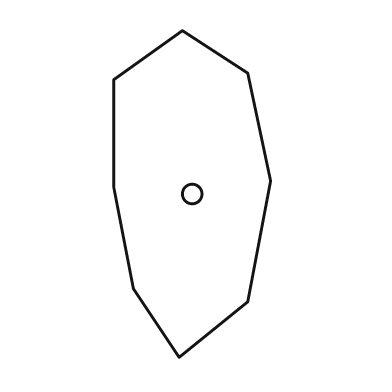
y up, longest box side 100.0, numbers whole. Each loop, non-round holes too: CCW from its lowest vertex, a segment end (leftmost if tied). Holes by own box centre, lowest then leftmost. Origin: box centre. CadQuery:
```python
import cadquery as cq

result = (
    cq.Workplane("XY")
    .moveTo(-4.0, -50.0)
    .lineTo(17.0, -33.0)
    .lineTo(24.0, 4.0)
    .lineTo(17.0, 37.0)
    .lineTo(-3.0, 50.0)
    .lineTo(-24.0, 35.0)
    .lineTo(-24.0, 2.0)
    .lineTo(-18.0, -29.0)
    .close()
    .moveTo(0.0, 0.0)
    .circle(3.0)
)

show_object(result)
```